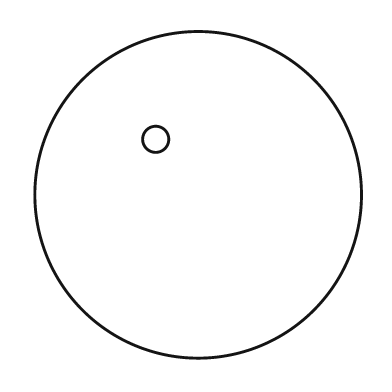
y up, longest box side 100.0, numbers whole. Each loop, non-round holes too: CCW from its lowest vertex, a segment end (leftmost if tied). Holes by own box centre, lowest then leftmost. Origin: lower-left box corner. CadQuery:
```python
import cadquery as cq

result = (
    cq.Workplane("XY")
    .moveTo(50.0, 50.0)
    .circle(50.0)
    .moveTo(37.0, 67.0)
    .circle(4.0)
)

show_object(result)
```